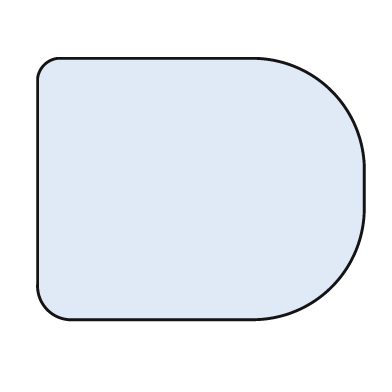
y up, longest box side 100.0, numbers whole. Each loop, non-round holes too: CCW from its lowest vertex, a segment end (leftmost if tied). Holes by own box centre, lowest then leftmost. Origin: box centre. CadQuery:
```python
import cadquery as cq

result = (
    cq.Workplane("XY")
    .moveTo(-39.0, -40.0)
    .lineTo(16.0, -40.0)
    .threePointArc((40.0, -30.0), (50.0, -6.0))
    .lineTo(50.0, 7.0)
    .threePointArc((40.0, 30.0), (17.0, 40.0))
    .lineTo(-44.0, 40.0)
    .threePointArc((-48.0, 38.0), (-50.0, 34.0))
    .lineTo(-50.0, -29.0)
    .threePointArc((-47.0, -37.0), (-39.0, -40.0))
    .close()
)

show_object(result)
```